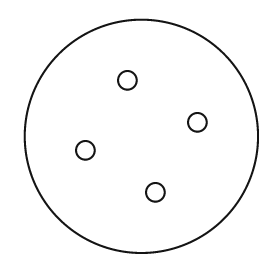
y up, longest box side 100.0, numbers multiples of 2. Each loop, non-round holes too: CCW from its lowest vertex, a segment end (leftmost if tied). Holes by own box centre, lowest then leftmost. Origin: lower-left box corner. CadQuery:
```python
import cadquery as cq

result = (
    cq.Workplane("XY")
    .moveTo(50.0, 50.0)
    .circle(50.0)
    .moveTo(56.0, 26.0)
    .circle(4.0)
    .moveTo(26.0, 44.0)
    .circle(4.0)
    .moveTo(74.0, 56.0)
    .circle(4.0)
    .moveTo(44.0, 74.0)
    .circle(4.0)
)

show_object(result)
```